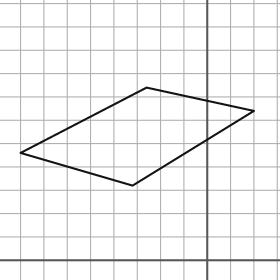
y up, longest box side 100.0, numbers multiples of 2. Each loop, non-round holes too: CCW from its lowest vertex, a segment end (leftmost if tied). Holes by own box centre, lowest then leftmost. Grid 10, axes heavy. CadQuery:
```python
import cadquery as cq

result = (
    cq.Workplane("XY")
    .moveTo(-32.0, 32.0)
    .lineTo(20.0, 64.0)
    .lineTo(-26.0, 74.0)
    .lineTo(-80.0, 46.0)
    .close()
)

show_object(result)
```